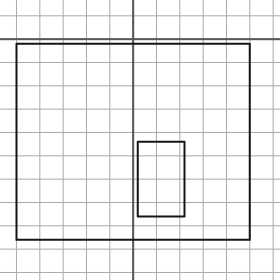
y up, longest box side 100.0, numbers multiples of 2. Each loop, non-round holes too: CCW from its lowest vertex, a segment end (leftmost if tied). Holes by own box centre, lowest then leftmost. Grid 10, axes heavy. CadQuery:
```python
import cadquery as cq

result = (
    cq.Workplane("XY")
    .moveTo(-50.0, -86.0)
    .lineTo(50.0, -86.0)
    .lineTo(50.0, -2.0)
    .lineTo(-50.0, -2.0)
    .close()
    .moveTo(2.0, -76.0)
    .lineTo(22.0, -76.0)
    .lineTo(22.0, -44.0)
    .lineTo(2.0, -44.0)
    .close()
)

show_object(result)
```